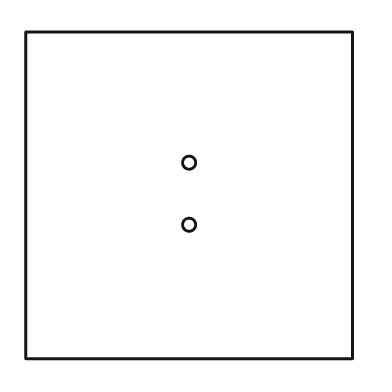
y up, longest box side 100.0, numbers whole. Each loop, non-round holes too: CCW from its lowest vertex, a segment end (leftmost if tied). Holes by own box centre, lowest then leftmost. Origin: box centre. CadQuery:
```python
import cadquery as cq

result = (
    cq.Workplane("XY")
    .moveTo(-50.0, -50.0)
    .lineTo(50.0, -50.0)
    .lineTo(50.0, 50.0)
    .lineTo(-50.0, 50.0)
    .close()
    .moveTo(0.0, -9.0)
    .circle(2.0)
    .moveTo(0.0, 10.0)
    .circle(2.0)
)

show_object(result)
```